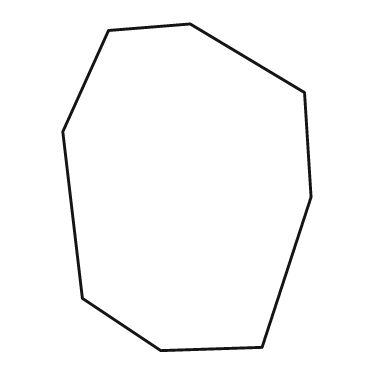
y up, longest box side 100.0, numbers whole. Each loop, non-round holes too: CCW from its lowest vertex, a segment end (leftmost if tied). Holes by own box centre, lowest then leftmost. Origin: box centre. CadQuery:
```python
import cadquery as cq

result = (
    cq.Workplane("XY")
    .moveTo(-8.0, -50.0)
    .lineTo(23.0, -49.0)
    .lineTo(38.0, -3.0)
    .lineTo(36.0, 29.0)
    .lineTo(1.0, 50.0)
    .lineTo(-24.0, 48.0)
    .lineTo(-38.0, 17.0)
    .lineTo(-32.0, -34.0)
    .close()
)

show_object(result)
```